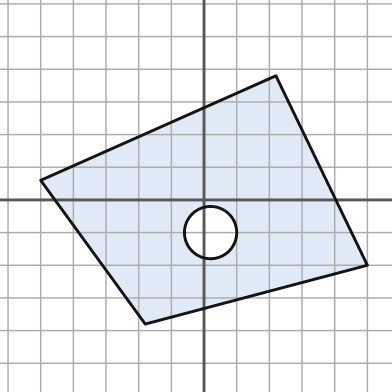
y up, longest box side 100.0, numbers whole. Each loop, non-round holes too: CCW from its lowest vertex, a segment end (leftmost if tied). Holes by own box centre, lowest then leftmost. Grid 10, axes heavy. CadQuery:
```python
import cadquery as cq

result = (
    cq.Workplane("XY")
    .moveTo(-18.0, -38.0)
    .lineTo(50.0, -20.0)
    .lineTo(22.0, 38.0)
    .lineTo(-50.0, 6.0)
    .close()
    .moveTo(2.0, -10.0)
    .circle(8.0)
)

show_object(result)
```